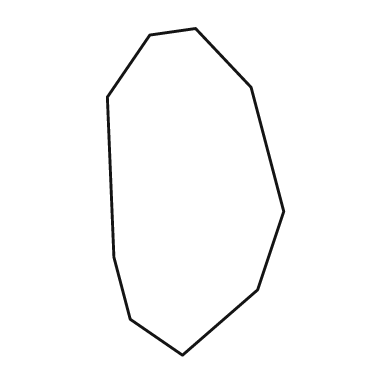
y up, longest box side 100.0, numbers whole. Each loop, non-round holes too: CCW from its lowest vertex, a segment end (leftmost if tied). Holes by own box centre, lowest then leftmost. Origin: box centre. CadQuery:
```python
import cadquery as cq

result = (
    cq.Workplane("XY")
    .moveTo(-4.0, -50.0)
    .lineTo(19.0, -30.0)
    .lineTo(27.0, -6.0)
    .lineTo(17.0, 32.0)
    .lineTo(0.0, 50.0)
    .lineTo(-14.0, 48.0)
    .lineTo(-27.0, 29.0)
    .lineTo(-25.0, -20.0)
    .lineTo(-20.0, -39.0)
    .close()
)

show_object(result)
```